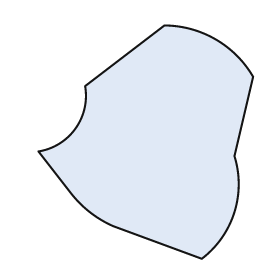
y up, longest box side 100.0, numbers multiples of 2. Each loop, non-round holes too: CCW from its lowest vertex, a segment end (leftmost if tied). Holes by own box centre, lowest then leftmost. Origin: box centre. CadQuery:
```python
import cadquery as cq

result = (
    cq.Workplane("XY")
    .moveTo(24.0, -50.0)
    .threePointArc((38.0, -30.0), (38.0, -6.0))
    .lineTo(46.0, 28.0)
    .threePointArc((30.0, 44.0), (8.0, 50.0))
    .lineTo(-26.0, 24.0)
    .threePointArc((-30.0, 6.0), (-46.0, -4.0))
    .lineTo(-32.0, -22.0)
    .threePointArc((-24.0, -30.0), (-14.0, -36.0))
    .close()
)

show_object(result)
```